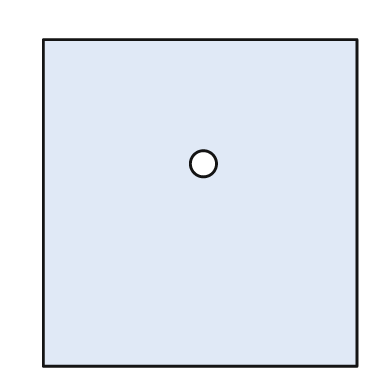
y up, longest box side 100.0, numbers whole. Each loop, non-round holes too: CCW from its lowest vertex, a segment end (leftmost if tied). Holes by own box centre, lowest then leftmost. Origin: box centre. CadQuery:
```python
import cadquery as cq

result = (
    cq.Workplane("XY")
    .moveTo(-48.0, -50.0)
    .lineTo(48.0, -50.0)
    .lineTo(48.0, 50.0)
    .lineTo(-48.0, 50.0)
    .close()
    .moveTo(1.0, 12.0)
    .circle(4.0)
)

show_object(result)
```